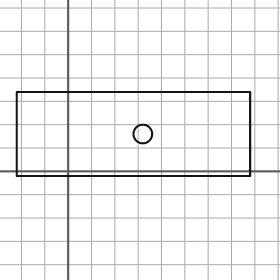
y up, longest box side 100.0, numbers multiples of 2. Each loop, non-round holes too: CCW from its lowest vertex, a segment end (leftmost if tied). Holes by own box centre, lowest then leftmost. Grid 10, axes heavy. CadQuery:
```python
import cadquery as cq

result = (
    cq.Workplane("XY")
    .moveTo(-22.0, -2.0)
    .lineTo(78.0, -2.0)
    .lineTo(78.0, 34.0)
    .lineTo(-22.0, 34.0)
    .close()
    .moveTo(32.0, 16.0)
    .circle(4.0)
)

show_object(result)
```